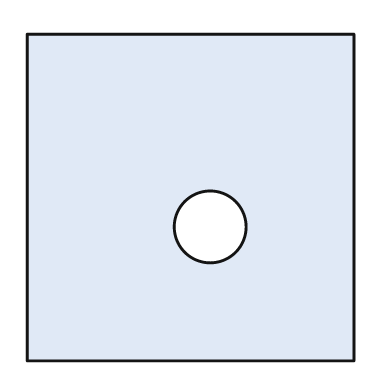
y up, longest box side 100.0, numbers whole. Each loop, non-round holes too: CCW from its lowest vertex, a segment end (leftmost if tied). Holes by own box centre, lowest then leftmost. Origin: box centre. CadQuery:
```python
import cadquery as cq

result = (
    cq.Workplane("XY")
    .moveTo(-50.0, -50.0)
    .lineTo(50.0, -50.0)
    .lineTo(50.0, 50.0)
    .lineTo(-50.0, 50.0)
    .close()
    .moveTo(6.0, -9.0)
    .circle(11.0)
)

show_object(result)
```